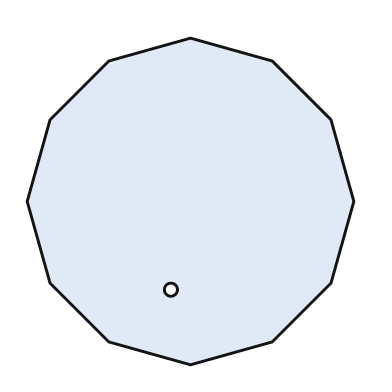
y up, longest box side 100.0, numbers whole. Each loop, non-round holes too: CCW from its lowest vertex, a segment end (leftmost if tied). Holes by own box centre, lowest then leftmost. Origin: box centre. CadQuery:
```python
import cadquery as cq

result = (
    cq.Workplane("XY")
    .moveTo(0.0, -50.0)
    .lineTo(25.0, -43.0)
    .lineTo(43.0, -25.0)
    .lineTo(50.0, 0.0)
    .lineTo(43.0, 25.0)
    .lineTo(25.0, 43.0)
    .lineTo(0.0, 50.0)
    .lineTo(-25.0, 43.0)
    .lineTo(-43.0, 25.0)
    .lineTo(-50.0, 0.0)
    .lineTo(-43.0, -25.0)
    .lineTo(-25.0, -43.0)
    .close()
    .moveTo(-6.0, -27.0)
    .circle(2.0)
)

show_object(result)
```